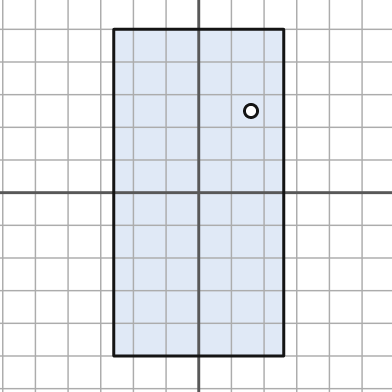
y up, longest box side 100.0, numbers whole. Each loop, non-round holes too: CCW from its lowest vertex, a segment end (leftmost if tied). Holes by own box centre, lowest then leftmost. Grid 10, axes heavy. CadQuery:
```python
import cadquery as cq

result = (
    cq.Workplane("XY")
    .moveTo(-26.0, -50.0)
    .lineTo(26.0, -50.0)
    .lineTo(26.0, 50.0)
    .lineTo(-26.0, 50.0)
    .close()
    .moveTo(16.0, 25.0)
    .circle(2.0)
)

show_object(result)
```